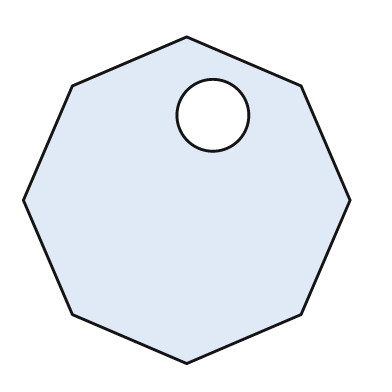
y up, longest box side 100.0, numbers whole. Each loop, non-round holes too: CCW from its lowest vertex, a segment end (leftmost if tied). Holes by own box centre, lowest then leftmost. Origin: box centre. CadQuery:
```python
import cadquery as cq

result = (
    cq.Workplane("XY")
    .moveTo(0.0, -50.0)
    .lineTo(35.0, -35.0)
    .lineTo(50.0, 0.0)
    .lineTo(35.0, 35.0)
    .lineTo(0.0, 50.0)
    .lineTo(-35.0, 35.0)
    .lineTo(-50.0, 0.0)
    .lineTo(-35.0, -35.0)
    .close()
    .moveTo(8.0, 26.0)
    .circle(11.0)
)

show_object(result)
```